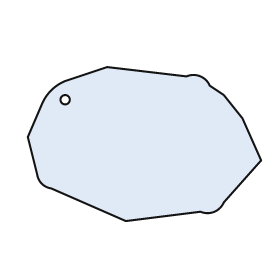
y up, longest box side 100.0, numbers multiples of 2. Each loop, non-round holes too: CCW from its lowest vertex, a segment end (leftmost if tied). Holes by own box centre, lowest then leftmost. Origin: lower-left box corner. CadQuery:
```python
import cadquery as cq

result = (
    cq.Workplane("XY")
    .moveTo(42.0, 0.0)
    .lineTo(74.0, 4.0)
    .threePointArc((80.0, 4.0), (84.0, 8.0))
    .lineTo(100.0, 26.0)
    .lineTo(92.0, 44.0)
    .lineTo(84.0, 54.0)
    .lineTo(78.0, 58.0)
    .threePointArc((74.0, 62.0), (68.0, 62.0))
    .lineTo(34.0, 66.0)
    .lineTo(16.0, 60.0)
    .threePointArc((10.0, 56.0), (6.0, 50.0))
    .lineTo(0.0, 36.0)
    .lineTo(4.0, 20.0)
    .threePointArc((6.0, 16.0), (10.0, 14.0))
    .close()
    .moveTo(16.0, 52.0)
    .circle(2.0)
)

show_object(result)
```